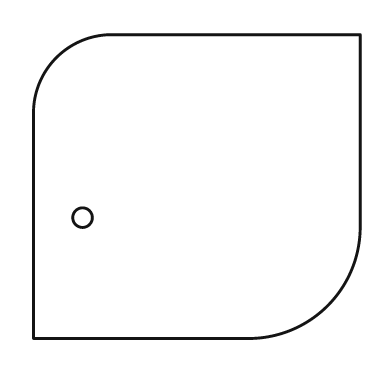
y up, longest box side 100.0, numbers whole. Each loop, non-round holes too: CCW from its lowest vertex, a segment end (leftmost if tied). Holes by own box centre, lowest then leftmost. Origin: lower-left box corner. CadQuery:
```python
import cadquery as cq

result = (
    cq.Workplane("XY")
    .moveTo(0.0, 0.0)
    .lineTo(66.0, 0.0)
    .threePointArc((90.0, 10.0), (100.0, 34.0))
    .lineTo(100.0, 93.0)
    .lineTo(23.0, 93.0)
    .threePointArc((7.0, 86.0), (0.0, 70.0))
    .close()
    .moveTo(15.0, 37.0)
    .circle(3.0)
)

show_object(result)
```